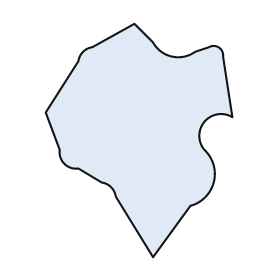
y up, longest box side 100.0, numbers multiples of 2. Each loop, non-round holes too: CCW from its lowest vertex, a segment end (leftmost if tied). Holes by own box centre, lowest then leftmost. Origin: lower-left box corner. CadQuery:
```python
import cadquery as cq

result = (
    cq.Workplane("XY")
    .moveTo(46.0, 0.0)
    .lineTo(62.0, 22.0)
    .threePointArc((72.0, 32.0), (68.0, 46.0))
    .threePointArc((68.0, 58.0), (80.0, 60.0))
    .lineTo(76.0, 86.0)
    .threePointArc((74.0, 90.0), (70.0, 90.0))
    .lineTo(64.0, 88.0)
    .threePointArc((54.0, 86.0), (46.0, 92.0))
    .lineTo(38.0, 100.0)
    .lineTo(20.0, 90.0)
    .threePointArc((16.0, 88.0), (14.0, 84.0))
    .lineTo(0.0, 62.0)
    .lineTo(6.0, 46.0)
    .threePointArc((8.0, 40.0), (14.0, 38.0))
    .lineTo(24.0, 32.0)
    .threePointArc((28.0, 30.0), (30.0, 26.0))
    .close()
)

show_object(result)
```